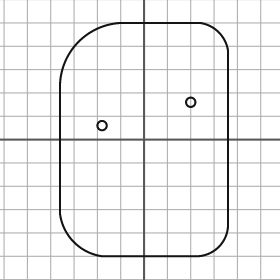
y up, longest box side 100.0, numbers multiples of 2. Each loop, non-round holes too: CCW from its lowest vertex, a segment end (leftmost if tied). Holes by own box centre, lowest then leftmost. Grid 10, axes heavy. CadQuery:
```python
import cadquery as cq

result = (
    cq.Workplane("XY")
    .moveTo(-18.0, -50.0)
    .lineTo(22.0, -50.0)
    .threePointArc((32.0, -46.0), (36.0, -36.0))
    .lineTo(36.0, 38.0)
    .threePointArc((32.0, 46.0), (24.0, 50.0))
    .lineTo(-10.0, 50.0)
    .threePointArc((-28.0, 42.0), (-36.0, 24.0))
    .lineTo(-36.0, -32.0)
    .threePointArc((-30.0, -44.0), (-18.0, -50.0))
    .close()
    .moveTo(-18.0, 6.0)
    .circle(2.0)
    .moveTo(20.0, 16.0)
    .circle(2.0)
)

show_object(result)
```